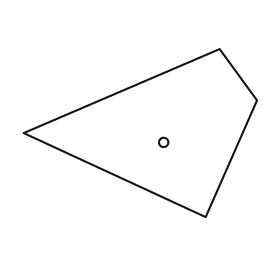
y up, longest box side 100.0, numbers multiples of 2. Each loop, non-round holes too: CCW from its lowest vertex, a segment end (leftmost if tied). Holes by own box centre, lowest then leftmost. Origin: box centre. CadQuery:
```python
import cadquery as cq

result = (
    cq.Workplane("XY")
    .moveTo(28.0, -36.0)
    .lineTo(50.0, 14.0)
    .lineTo(34.0, 36.0)
    .lineTo(-50.0, 0.0)
    .close()
    .moveTo(10.0, -4.0)
    .circle(2.0)
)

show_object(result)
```